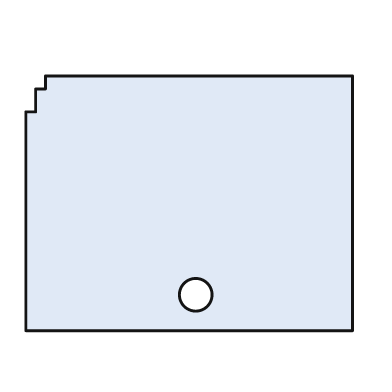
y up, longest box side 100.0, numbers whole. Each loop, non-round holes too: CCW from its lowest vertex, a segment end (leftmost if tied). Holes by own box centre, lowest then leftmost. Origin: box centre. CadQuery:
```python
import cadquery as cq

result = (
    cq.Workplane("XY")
    .moveTo(-50.0, -39.0)
    .lineTo(50.0, -39.0)
    .lineTo(50.0, 39.0)
    .lineTo(-44.0, 39.0)
    .lineTo(-44.0, 35.0)
    .lineTo(-47.0, 35.0)
    .lineTo(-47.0, 28.0)
    .lineTo(-50.0, 28.0)
    .close()
    .moveTo(2.0, -28.0)
    .circle(5.0)
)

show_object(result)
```